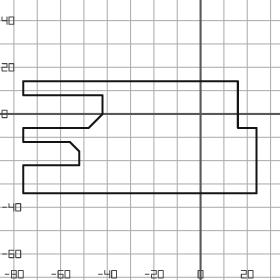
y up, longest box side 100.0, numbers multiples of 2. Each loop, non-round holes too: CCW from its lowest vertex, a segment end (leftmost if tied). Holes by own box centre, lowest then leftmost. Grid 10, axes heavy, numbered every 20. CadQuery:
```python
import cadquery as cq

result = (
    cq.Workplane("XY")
    .moveTo(-76.0, -34.0)
    .lineTo(24.0, -34.0)
    .lineTo(24.0, -6.0)
    .lineTo(16.0, -6.0)
    .lineTo(16.0, 14.0)
    .lineTo(-76.0, 14.0)
    .lineTo(-76.0, 8.0)
    .lineTo(-42.0, 8.0)
    .lineTo(-42.0, 0.0)
    .lineTo(-48.0, -6.0)
    .lineTo(-76.0, -6.0)
    .lineTo(-76.0, -12.0)
    .lineTo(-56.0, -12.0)
    .lineTo(-52.0, -16.0)
    .lineTo(-52.0, -22.0)
    .lineTo(-76.0, -22.0)
    .close()
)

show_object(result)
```